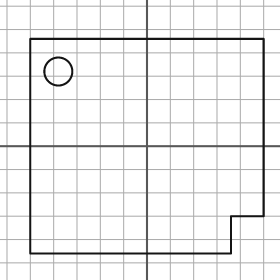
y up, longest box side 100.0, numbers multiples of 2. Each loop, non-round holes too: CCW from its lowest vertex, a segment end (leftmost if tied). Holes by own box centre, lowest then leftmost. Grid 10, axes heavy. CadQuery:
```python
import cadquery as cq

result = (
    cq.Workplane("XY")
    .moveTo(-50.0, -46.0)
    .lineTo(36.0, -46.0)
    .lineTo(36.0, -30.0)
    .lineTo(50.0, -30.0)
    .lineTo(50.0, 46.0)
    .lineTo(-50.0, 46.0)
    .close()
    .moveTo(-38.0, 32.0)
    .circle(6.0)
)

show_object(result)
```